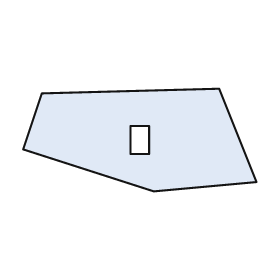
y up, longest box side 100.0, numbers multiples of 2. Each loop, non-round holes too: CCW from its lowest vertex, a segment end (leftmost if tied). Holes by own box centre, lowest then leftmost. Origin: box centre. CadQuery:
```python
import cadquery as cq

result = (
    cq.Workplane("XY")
    .moveTo(6.0, -22.0)
    .lineTo(50.0, -18.0)
    .lineTo(34.0, 22.0)
    .lineTo(-42.0, 20.0)
    .lineTo(-50.0, -4.0)
    .close()
    .moveTo(-4.0, -6.0)
    .lineTo(4.0, -6.0)
    .lineTo(4.0, 6.0)
    .lineTo(-4.0, 6.0)
    .close()
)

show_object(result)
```